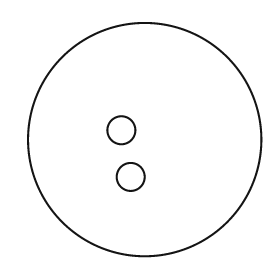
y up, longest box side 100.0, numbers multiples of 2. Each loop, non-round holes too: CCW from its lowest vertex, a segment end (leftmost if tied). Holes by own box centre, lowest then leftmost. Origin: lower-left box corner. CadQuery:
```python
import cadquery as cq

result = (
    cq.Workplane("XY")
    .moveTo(50.0, 50.0)
    .circle(50.0)
    .moveTo(44.0, 34.0)
    .circle(6.0)
    .moveTo(40.0, 54.0)
    .circle(6.0)
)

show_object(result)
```